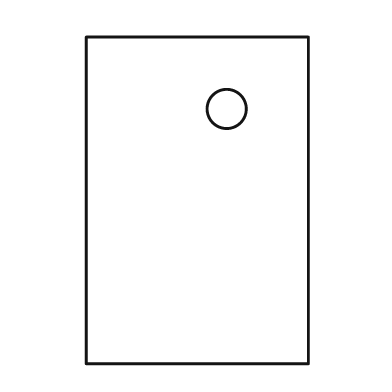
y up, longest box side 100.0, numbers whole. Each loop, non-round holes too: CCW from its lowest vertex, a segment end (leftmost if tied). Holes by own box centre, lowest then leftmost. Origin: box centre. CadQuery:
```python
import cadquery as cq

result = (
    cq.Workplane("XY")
    .moveTo(-34.0, -50.0)
    .lineTo(34.0, -50.0)
    .lineTo(34.0, 50.0)
    .lineTo(-34.0, 50.0)
    .close()
    .moveTo(9.0, 28.0)
    .circle(6.0)
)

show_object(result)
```